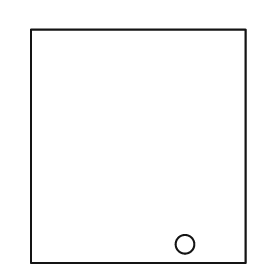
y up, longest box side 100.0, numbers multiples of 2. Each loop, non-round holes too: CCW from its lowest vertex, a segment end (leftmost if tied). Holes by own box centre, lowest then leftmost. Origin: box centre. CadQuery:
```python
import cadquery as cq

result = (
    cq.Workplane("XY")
    .moveTo(-46.0, -50.0)
    .lineTo(46.0, -50.0)
    .lineTo(46.0, 50.0)
    .lineTo(-46.0, 50.0)
    .close()
    .moveTo(20.0, -42.0)
    .circle(4.0)
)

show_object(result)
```